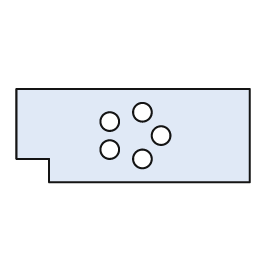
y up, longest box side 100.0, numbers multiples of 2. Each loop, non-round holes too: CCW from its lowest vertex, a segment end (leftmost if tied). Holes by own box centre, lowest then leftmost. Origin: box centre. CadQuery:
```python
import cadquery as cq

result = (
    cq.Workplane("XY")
    .moveTo(-36.0, -20.0)
    .lineTo(50.0, -20.0)
    .lineTo(50.0, 20.0)
    .lineTo(-50.0, 20.0)
    .lineTo(-50.0, -10.0)
    .lineTo(-36.0, -10.0)
    .close()
    .moveTo(4.0, -10.0)
    .circle(4.0)
    .moveTo(-10.0, -6.0)
    .circle(4.0)
    .moveTo(12.0, 0.0)
    .circle(4.0)
    .moveTo(-10.0, 6.0)
    .circle(4.0)
    .moveTo(4.0, 10.0)
    .circle(4.0)
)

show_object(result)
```